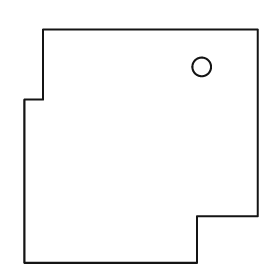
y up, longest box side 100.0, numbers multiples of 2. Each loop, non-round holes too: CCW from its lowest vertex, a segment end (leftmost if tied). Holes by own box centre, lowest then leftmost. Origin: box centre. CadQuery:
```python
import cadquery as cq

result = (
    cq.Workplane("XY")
    .moveTo(-50.0, -50.0)
    .lineTo(24.0, -50.0)
    .lineTo(24.0, -30.0)
    .lineTo(50.0, -30.0)
    .lineTo(50.0, 50.0)
    .lineTo(-42.0, 50.0)
    .lineTo(-42.0, 20.0)
    .lineTo(-50.0, 20.0)
    .close()
    .moveTo(26.0, 34.0)
    .circle(4.0)
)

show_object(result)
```